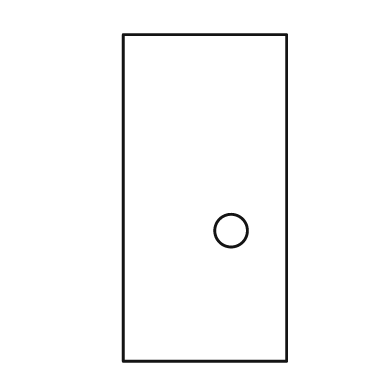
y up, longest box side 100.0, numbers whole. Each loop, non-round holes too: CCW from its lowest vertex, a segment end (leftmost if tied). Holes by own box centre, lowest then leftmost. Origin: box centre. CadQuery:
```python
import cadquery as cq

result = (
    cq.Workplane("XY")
    .moveTo(-25.0, -50.0)
    .lineTo(25.0, -50.0)
    .lineTo(25.0, 50.0)
    .lineTo(-25.0, 50.0)
    .close()
    .moveTo(8.0, -10.0)
    .circle(5.0)
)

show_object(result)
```